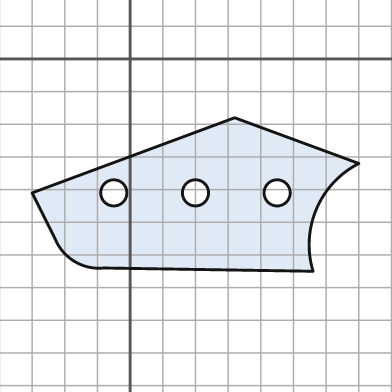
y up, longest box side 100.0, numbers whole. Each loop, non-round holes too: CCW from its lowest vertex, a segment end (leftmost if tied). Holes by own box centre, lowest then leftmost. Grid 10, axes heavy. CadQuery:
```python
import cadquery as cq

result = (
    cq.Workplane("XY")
    .moveTo(56.0, -65.0)
    .threePointArc((57.0, -46.0), (70.0, -32.0))
    .lineTo(32.0, -18.0)
    .lineTo(-30.0, -41.0)
    .lineTo(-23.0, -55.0)
    .threePointArc((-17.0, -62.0), (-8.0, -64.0))
    .close()
    .moveTo(-5.0, -41.0)
    .circle(4.0)
    .moveTo(20.0, -41.0)
    .circle(4.0)
    .moveTo(45.0, -41.0)
    .circle(4.0)
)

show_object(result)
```